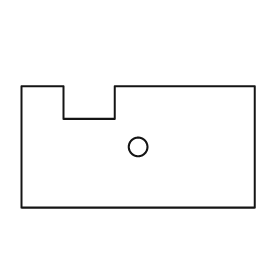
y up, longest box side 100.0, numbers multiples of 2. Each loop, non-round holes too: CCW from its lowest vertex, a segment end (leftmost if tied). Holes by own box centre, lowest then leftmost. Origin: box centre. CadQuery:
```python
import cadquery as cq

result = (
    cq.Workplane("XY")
    .moveTo(-50.0, -26.0)
    .lineTo(50.0, -26.0)
    .lineTo(50.0, 26.0)
    .lineTo(-10.0, 26.0)
    .lineTo(-10.0, 12.0)
    .lineTo(-32.0, 12.0)
    .lineTo(-32.0, 26.0)
    .lineTo(-50.0, 26.0)
    .close()
    .moveTo(0.0, 0.0)
    .circle(4.0)
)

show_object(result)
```